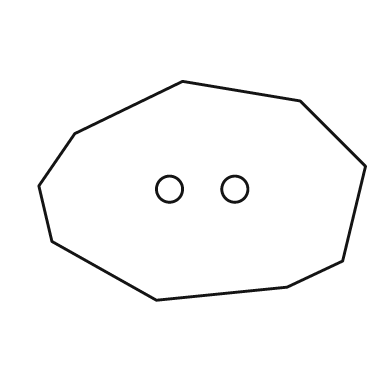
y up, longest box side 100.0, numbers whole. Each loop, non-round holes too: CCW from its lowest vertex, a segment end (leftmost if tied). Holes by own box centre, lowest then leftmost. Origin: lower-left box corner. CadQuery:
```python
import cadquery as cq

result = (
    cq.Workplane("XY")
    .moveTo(36.0, 0.0)
    .lineTo(76.0, 4.0)
    .lineTo(93.0, 12.0)
    .lineTo(100.0, 41.0)
    .lineTo(80.0, 61.0)
    .lineTo(44.0, 67.0)
    .lineTo(11.0, 51.0)
    .lineTo(0.0, 35.0)
    .lineTo(4.0, 18.0)
    .close()
    .moveTo(40.0, 34.0)
    .circle(4.0)
    .moveTo(60.0, 34.0)
    .circle(4.0)
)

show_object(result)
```